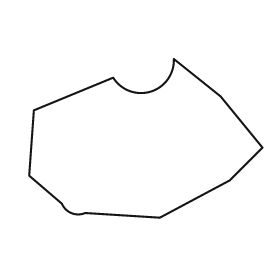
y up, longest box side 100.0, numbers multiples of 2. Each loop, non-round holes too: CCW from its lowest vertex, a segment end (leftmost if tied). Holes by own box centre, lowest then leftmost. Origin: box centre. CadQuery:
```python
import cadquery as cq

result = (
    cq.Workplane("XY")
    .moveTo(6.0, -34.0)
    .lineTo(36.0, -18.0)
    .lineTo(50.0, -4.0)
    .lineTo(32.0, 18.0)
    .lineTo(12.0, 34.0)
    .threePointArc((2.0, 20.0), (-14.0, 26.0))
    .lineTo(-48.0, 12.0)
    .lineTo(-50.0, -16.0)
    .lineTo(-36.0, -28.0)
    .threePointArc((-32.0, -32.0), (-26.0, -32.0))
    .close()
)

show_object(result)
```